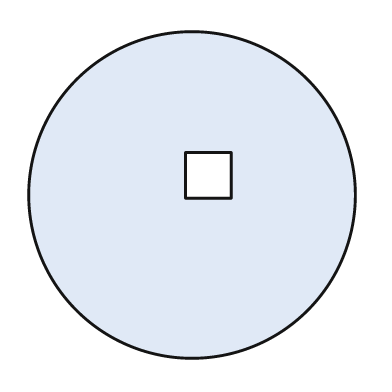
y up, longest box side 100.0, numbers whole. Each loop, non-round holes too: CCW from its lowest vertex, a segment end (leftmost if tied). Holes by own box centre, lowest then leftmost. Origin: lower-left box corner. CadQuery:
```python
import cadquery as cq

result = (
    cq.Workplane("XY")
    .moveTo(50.0, 50.0)
    .circle(50.0)
    .moveTo(48.0, 49.0)
    .lineTo(62.0, 49.0)
    .lineTo(62.0, 63.0)
    .lineTo(48.0, 63.0)
    .close()
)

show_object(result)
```